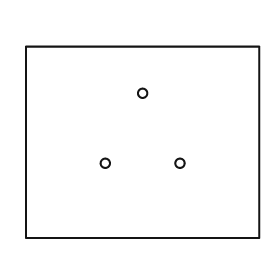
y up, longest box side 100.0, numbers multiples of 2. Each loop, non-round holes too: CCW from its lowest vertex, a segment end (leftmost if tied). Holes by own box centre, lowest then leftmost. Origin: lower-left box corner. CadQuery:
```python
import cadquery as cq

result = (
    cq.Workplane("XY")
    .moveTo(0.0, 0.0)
    .lineTo(100.0, 0.0)
    .lineTo(100.0, 82.0)
    .lineTo(0.0, 82.0)
    .close()
    .moveTo(34.0, 32.0)
    .circle(2.0)
    .moveTo(66.0, 32.0)
    .circle(2.0)
    .moveTo(50.0, 62.0)
    .circle(2.0)
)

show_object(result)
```